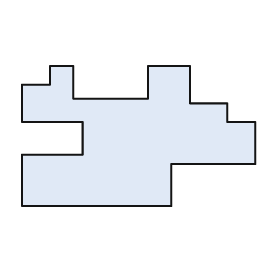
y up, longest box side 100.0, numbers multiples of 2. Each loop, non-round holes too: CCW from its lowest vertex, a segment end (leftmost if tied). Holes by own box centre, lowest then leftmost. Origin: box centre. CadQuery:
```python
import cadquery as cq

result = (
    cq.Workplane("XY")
    .moveTo(-50.0, -30.0)
    .lineTo(14.0, -30.0)
    .lineTo(14.0, -12.0)
    .lineTo(50.0, -12.0)
    .lineTo(50.0, 6.0)
    .lineTo(38.0, 6.0)
    .lineTo(38.0, 14.0)
    .lineTo(22.0, 14.0)
    .lineTo(22.0, 30.0)
    .lineTo(4.0, 30.0)
    .lineTo(4.0, 16.0)
    .lineTo(-28.0, 16.0)
    .lineTo(-28.0, 30.0)
    .lineTo(-38.0, 30.0)
    .lineTo(-38.0, 22.0)
    .lineTo(-50.0, 22.0)
    .lineTo(-50.0, 6.0)
    .lineTo(-24.0, 6.0)
    .lineTo(-24.0, -8.0)
    .lineTo(-50.0, -8.0)
    .close()
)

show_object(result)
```